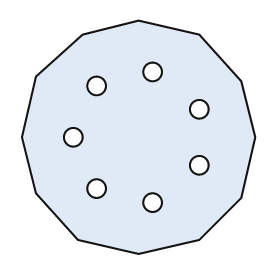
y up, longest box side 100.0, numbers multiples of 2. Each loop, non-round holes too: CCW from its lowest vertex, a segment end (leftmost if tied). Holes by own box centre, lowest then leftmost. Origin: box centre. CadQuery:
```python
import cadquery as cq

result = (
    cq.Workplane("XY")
    .moveTo(0.0, -50.0)
    .lineTo(26.0, -44.0)
    .lineTo(44.0, -26.0)
    .lineTo(50.0, 0.0)
    .lineTo(44.0, 24.0)
    .lineTo(26.0, 44.0)
    .lineTo(0.0, 50.0)
    .lineTo(-24.0, 44.0)
    .lineTo(-44.0, 26.0)
    .lineTo(-50.0, 0.0)
    .lineTo(-44.0, -24.0)
    .lineTo(-26.0, -44.0)
    .close()
    .moveTo(6.0, -28.0)
    .circle(4.0)
    .moveTo(-18.0, -22.0)
    .circle(4.0)
    .moveTo(26.0, -12.0)
    .circle(4.0)
    .moveTo(-28.0, 0.0)
    .circle(4.0)
    .moveTo(26.0, 12.0)
    .circle(4.0)
    .moveTo(-18.0, 22.0)
    .circle(4.0)
    .moveTo(6.0, 28.0)
    .circle(4.0)
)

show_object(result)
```